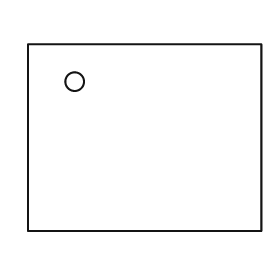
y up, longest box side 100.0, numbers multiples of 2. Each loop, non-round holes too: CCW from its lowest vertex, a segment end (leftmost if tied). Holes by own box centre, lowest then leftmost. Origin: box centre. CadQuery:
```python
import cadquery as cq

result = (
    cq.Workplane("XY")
    .moveTo(-50.0, -40.0)
    .lineTo(50.0, -40.0)
    .lineTo(50.0, 40.0)
    .lineTo(-50.0, 40.0)
    .close()
    .moveTo(-30.0, 24.0)
    .circle(4.0)
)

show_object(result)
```